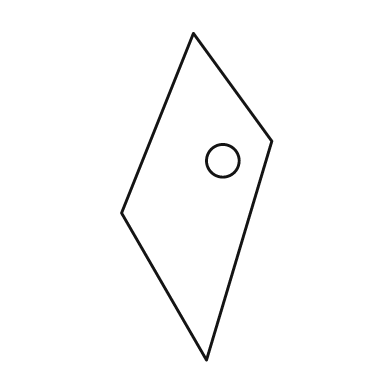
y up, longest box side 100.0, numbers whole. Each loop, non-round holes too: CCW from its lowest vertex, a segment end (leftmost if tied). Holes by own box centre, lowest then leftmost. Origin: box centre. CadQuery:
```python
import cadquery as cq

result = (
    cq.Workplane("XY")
    .moveTo(3.0, -50.0)
    .lineTo(23.0, 17.0)
    .lineTo(-1.0, 50.0)
    .lineTo(-23.0, -5.0)
    .close()
    .moveTo(8.0, 11.0)
    .circle(5.0)
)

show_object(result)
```